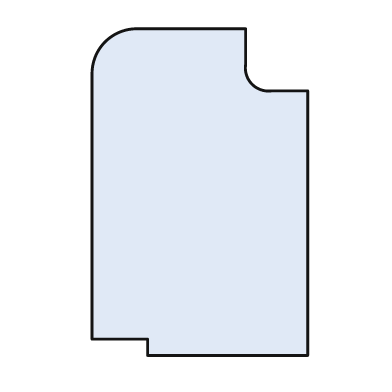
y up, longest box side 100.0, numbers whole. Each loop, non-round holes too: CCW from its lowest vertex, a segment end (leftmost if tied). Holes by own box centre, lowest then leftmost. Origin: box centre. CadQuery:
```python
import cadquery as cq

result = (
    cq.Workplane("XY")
    .moveTo(-16.0, -50.0)
    .lineTo(33.0, -50.0)
    .lineTo(33.0, 31.0)
    .lineTo(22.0, 31.0)
    .threePointArc((16.0, 33.0), (14.0, 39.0))
    .lineTo(14.0, 50.0)
    .lineTo(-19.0, 50.0)
    .threePointArc((-29.0, 46.0), (-33.0, 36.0))
    .lineTo(-33.0, -45.0)
    .lineTo(-16.0, -45.0)
    .close()
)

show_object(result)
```